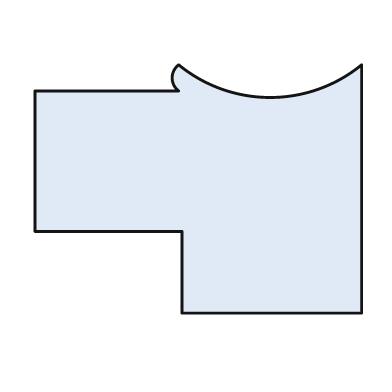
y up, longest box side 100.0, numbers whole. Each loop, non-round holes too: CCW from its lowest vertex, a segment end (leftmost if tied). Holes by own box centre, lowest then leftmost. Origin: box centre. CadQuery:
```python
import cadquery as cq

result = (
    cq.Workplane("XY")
    .moveTo(-5.0, -38.0)
    .lineTo(50.0, -38.0)
    .lineTo(50.0, 38.0)
    .threePointArc((22.0, 28.0), (-6.0, 38.0))
    .threePointArc((-8.0, 34.0), (-6.0, 30.0))
    .lineTo(-50.0, 30.0)
    .lineTo(-50.0, -13.0)
    .lineTo(-5.0, -13.0)
    .close()
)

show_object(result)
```